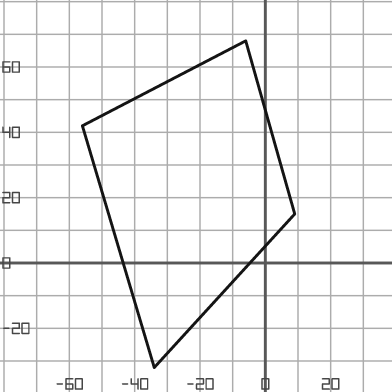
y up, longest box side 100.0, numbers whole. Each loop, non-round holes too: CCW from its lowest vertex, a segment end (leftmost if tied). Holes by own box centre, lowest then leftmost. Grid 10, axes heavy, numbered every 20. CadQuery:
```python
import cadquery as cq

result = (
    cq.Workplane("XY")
    .moveTo(-34.0, -32.0)
    .lineTo(9.0, 15.0)
    .lineTo(-6.0, 68.0)
    .lineTo(-56.0, 42.0)
    .close()
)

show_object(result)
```